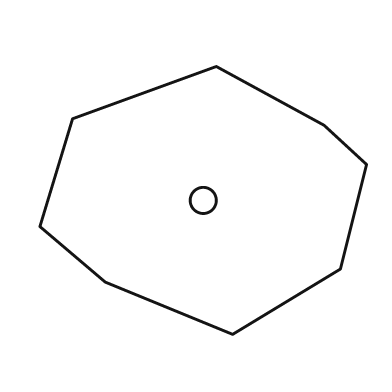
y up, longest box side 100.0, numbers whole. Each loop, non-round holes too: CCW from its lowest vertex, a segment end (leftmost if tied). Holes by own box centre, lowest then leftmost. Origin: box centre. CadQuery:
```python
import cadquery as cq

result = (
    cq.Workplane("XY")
    .moveTo(9.0, -41.0)
    .lineTo(42.0, -21.0)
    .lineTo(50.0, 11.0)
    .lineTo(37.0, 23.0)
    .lineTo(4.0, 41.0)
    .lineTo(-40.0, 25.0)
    .lineTo(-50.0, -8.0)
    .lineTo(-30.0, -25.0)
    .close()
    .moveTo(0.0, 0.0)
    .circle(4.0)
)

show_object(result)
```